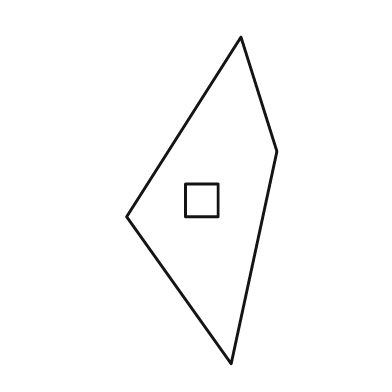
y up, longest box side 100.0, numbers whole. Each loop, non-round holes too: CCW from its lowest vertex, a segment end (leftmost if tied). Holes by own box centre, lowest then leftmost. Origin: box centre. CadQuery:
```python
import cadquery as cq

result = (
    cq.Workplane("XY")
    .moveTo(9.0, -50.0)
    .lineTo(23.0, 15.0)
    .lineTo(12.0, 50.0)
    .lineTo(-23.0, -5.0)
    .close()
    .moveTo(-5.0, -5.0)
    .lineTo(5.0, -5.0)
    .lineTo(5.0, 5.0)
    .lineTo(-5.0, 5.0)
    .close()
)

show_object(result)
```